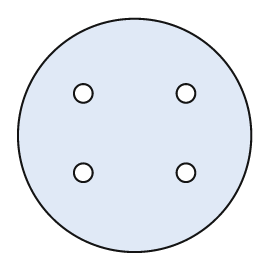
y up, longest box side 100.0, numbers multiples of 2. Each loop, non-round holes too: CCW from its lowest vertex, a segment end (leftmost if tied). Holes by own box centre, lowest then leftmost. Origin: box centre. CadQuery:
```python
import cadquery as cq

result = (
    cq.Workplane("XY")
    .moveTo(0.0, 0.0)
    .circle(50.0)
    .moveTo(-22.0, -16.0)
    .circle(4.0)
    .moveTo(22.0, -16.0)
    .circle(4.0)
    .moveTo(-22.0, 18.0)
    .circle(4.0)
    .moveTo(22.0, 18.0)
    .circle(4.0)
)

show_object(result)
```